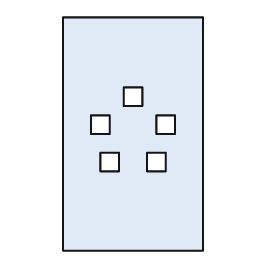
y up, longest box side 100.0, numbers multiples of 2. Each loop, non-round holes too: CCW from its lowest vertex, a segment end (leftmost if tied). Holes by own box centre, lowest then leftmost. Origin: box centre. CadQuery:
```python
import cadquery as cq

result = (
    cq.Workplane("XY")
    .moveTo(-30.0, -50.0)
    .lineTo(30.0, -50.0)
    .lineTo(30.0, 50.0)
    .lineTo(-30.0, 50.0)
    .close()
    .moveTo(-14.0, -16.0)
    .lineTo(-6.0, -16.0)
    .lineTo(-6.0, -8.0)
    .lineTo(-14.0, -8.0)
    .close()
    .moveTo(6.0, -16.0)
    .lineTo(14.0, -16.0)
    .lineTo(14.0, -8.0)
    .lineTo(6.0, -8.0)
    .close()
    .moveTo(-18.0, 0.0)
    .lineTo(-10.0, 0.0)
    .lineTo(-10.0, 8.0)
    .lineTo(-18.0, 8.0)
    .close()
    .moveTo(10.0, 0.0)
    .lineTo(18.0, 0.0)
    .lineTo(18.0, 8.0)
    .lineTo(10.0, 8.0)
    .close()
    .moveTo(-4.0, 12.0)
    .lineTo(4.0, 12.0)
    .lineTo(4.0, 20.0)
    .lineTo(-4.0, 20.0)
    .close()
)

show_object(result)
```